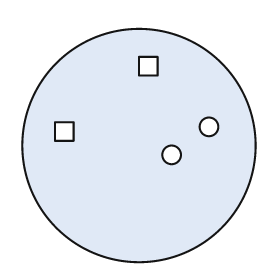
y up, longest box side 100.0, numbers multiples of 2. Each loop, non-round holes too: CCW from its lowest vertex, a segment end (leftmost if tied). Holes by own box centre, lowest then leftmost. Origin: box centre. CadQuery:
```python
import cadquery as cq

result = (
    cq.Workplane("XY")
    .moveTo(0.0, 0.0)
    .circle(50.0)
    .moveTo(14.0, -4.0)
    .circle(4.0)
    .moveTo(-36.0, 2.0)
    .lineTo(-28.0, 2.0)
    .lineTo(-28.0, 10.0)
    .lineTo(-36.0, 10.0)
    .close()
    .moveTo(30.0, 8.0)
    .circle(4.0)
    .moveTo(0.0, 30.0)
    .lineTo(8.0, 30.0)
    .lineTo(8.0, 38.0)
    .lineTo(0.0, 38.0)
    .close()
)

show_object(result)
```